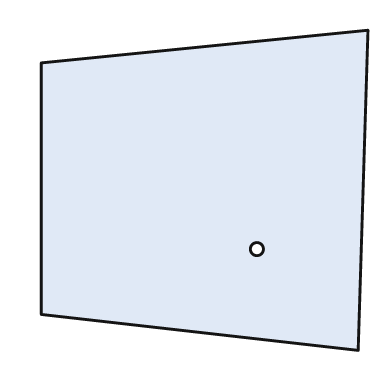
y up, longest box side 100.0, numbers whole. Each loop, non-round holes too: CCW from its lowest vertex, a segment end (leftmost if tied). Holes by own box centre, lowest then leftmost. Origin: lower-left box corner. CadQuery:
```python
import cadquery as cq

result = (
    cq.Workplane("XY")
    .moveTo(97.0, 0.0)
    .lineTo(100.0, 98.0)
    .lineTo(0.0, 88.0)
    .lineTo(0.0, 11.0)
    .close()
    .moveTo(66.0, 31.0)
    .circle(2.0)
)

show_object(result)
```